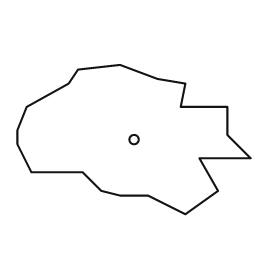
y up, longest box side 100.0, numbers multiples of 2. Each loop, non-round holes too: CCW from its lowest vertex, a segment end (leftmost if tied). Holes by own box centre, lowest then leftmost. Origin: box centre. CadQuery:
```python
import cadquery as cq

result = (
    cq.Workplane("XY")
    .moveTo(22.0, -32.0)
    .lineTo(36.0, -22.0)
    .lineTo(28.0, -8.0)
    .lineTo(50.0, -8.0)
    .lineTo(40.0, 2.0)
    .lineTo(40.0, 14.0)
    .lineTo(20.0, 14.0)
    .lineTo(22.0, 24.0)
    .lineTo(10.0, 26.0)
    .lineTo(-6.0, 32.0)
    .lineTo(-24.0, 30.0)
    .lineTo(-28.0, 24.0)
    .lineTo(-46.0, 14.0)
    .lineTo(-50.0, 4.0)
    .lineTo(-50.0, -2.0)
    .lineTo(-44.0, -14.0)
    .lineTo(-22.0, -14.0)
    .lineTo(-14.0, -22.0)
    .lineTo(-6.0, -24.0)
    .lineTo(6.0, -24.0)
    .close()
    .moveTo(0.0, 0.0)
    .circle(2.0)
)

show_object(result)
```